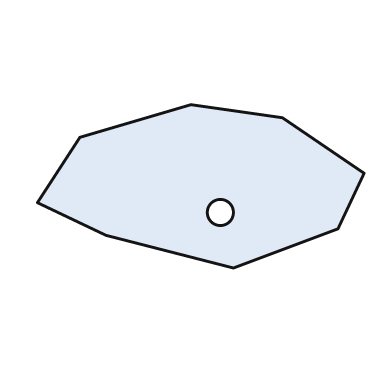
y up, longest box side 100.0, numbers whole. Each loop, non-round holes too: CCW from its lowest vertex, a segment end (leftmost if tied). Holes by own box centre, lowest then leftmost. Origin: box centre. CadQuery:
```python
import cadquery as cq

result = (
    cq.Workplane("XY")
    .moveTo(10.0, -25.0)
    .lineTo(42.0, -13.0)
    .lineTo(50.0, 4.0)
    .lineTo(25.0, 21.0)
    .lineTo(-3.0, 25.0)
    .lineTo(-37.0, 15.0)
    .lineTo(-50.0, -5.0)
    .lineTo(-29.0, -15.0)
    .close()
    .moveTo(6.0, -8.0)
    .circle(4.0)
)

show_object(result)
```